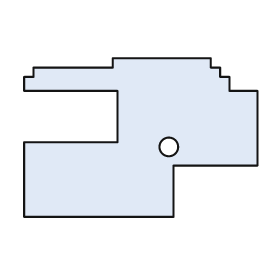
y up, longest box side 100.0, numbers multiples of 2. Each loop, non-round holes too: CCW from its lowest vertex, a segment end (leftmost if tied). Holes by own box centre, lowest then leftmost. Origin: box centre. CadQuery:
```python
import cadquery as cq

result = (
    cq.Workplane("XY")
    .moveTo(-50.0, -34.0)
    .lineTo(14.0, -34.0)
    .lineTo(14.0, -12.0)
    .lineTo(50.0, -12.0)
    .lineTo(50.0, 20.0)
    .lineTo(38.0, 20.0)
    .lineTo(38.0, 26.0)
    .lineTo(34.0, 26.0)
    .lineTo(34.0, 30.0)
    .lineTo(30.0, 30.0)
    .lineTo(30.0, 34.0)
    .lineTo(-12.0, 34.0)
    .lineTo(-12.0, 30.0)
    .lineTo(-46.0, 30.0)
    .lineTo(-46.0, 26.0)
    .lineTo(-50.0, 26.0)
    .lineTo(-50.0, 20.0)
    .lineTo(-10.0, 20.0)
    .lineTo(-10.0, -2.0)
    .lineTo(-50.0, -2.0)
    .close()
    .moveTo(12.0, -4.0)
    .circle(4.0)
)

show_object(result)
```